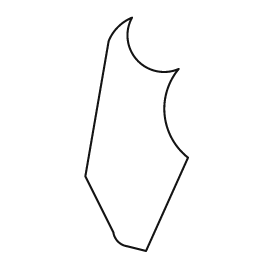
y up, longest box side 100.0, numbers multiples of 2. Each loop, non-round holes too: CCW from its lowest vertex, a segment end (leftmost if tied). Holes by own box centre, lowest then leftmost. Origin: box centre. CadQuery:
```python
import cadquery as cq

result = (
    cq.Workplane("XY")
    .moveTo(4.0, -50.0)
    .lineTo(22.0, -10.0)
    .threePointArc((12.0, 8.0), (18.0, 28.0))
    .threePointArc((0.0, 32.0), (-2.0, 50.0))
    .threePointArc((-8.0, 46.0), (-12.0, 40.0))
    .lineTo(-22.0, -18.0)
    .lineTo(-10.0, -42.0)
    .threePointArc((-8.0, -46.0), (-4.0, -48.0))
    .close()
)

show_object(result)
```